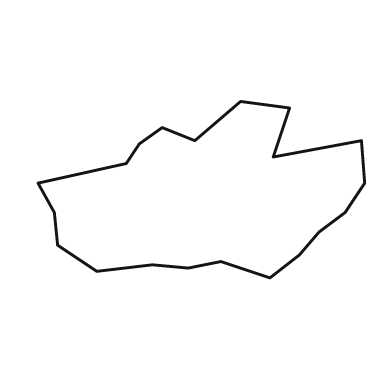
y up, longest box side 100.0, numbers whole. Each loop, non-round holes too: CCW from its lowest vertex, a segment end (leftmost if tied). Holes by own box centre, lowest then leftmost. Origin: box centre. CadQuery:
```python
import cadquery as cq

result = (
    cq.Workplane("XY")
    .moveTo(21.0, -27.0)
    .lineTo(30.0, -20.0)
    .lineTo(36.0, -13.0)
    .lineTo(44.0, -7.0)
    .lineTo(50.0, 2.0)
    .lineTo(49.0, 15.0)
    .lineTo(22.0, 10.0)
    .lineTo(27.0, 25.0)
    .lineTo(12.0, 27.0)
    .lineTo(-2.0, 15.0)
    .lineTo(-12.0, 19.0)
    .lineTo(-19.0, 14.0)
    .lineTo(-23.0, 8.0)
    .lineTo(-50.0, 2.0)
    .lineTo(-45.0, -7.0)
    .lineTo(-44.0, -17.0)
    .lineTo(-32.0, -25.0)
    .lineTo(-15.0, -23.0)
    .lineTo(-4.0, -24.0)
    .lineTo(6.0, -22.0)
    .close()
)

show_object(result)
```